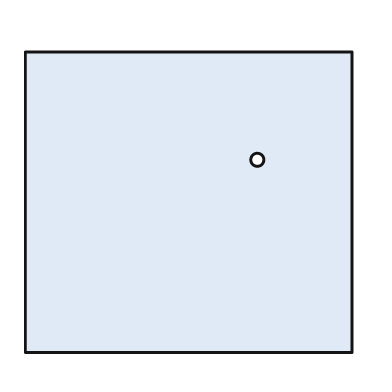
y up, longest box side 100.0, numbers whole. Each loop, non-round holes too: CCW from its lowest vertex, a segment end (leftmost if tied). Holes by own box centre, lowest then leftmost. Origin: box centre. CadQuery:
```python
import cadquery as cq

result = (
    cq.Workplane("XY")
    .moveTo(-50.0, -46.0)
    .lineTo(50.0, -46.0)
    .lineTo(50.0, 46.0)
    .lineTo(-50.0, 46.0)
    .close()
    .moveTo(21.0, 13.0)
    .circle(2.0)
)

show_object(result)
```